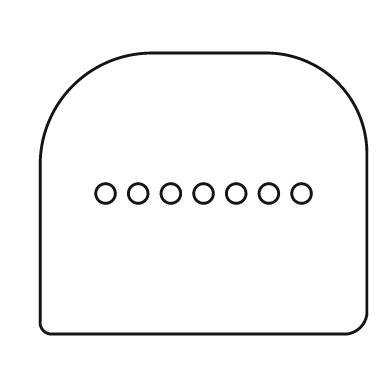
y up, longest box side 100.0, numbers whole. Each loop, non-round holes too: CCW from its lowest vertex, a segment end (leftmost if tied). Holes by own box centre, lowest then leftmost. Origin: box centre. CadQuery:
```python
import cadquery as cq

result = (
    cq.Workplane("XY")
    .moveTo(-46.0, -43.0)
    .lineTo(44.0, -43.0)
    .threePointArc((48.0, -41.0), (50.0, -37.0))
    .lineTo(50.0, 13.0)
    .threePointArc((41.0, 34.0), (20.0, 43.0))
    .lineTo(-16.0, 43.0)
    .threePointArc((-40.0, 33.0), (-50.0, 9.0))
    .lineTo(-50.0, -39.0)
    .threePointArc((-49.0, -42.0), (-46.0, -43.0))
    .close()
    .moveTo(-30.0, 0.0)
    .circle(3.0)
    .moveTo(-20.0, 0.0)
    .circle(3.0)
    .moveTo(-10.0, 0.0)
    .circle(3.0)
    .moveTo(0.0, 0.0)
    .circle(3.0)
    .moveTo(10.0, 0.0)
    .circle(3.0)
    .moveTo(20.0, 0.0)
    .circle(3.0)
    .moveTo(30.0, 0.0)
    .circle(3.0)
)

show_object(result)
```